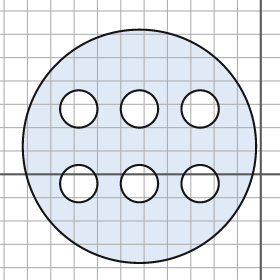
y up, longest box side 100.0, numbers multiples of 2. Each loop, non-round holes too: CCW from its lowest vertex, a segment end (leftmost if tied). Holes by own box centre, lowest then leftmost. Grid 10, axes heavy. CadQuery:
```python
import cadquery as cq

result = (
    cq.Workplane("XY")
    .moveTo(-52.0, 12.0)
    .circle(50.0)
    .moveTo(-78.0, -4.0)
    .circle(8.0)
    .moveTo(-52.0, -4.0)
    .circle(8.0)
    .moveTo(-26.0, -4.0)
    .circle(8.0)
    .moveTo(-78.0, 28.0)
    .circle(8.0)
    .moveTo(-52.0, 28.0)
    .circle(8.0)
    .moveTo(-26.0, 28.0)
    .circle(8.0)
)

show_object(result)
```